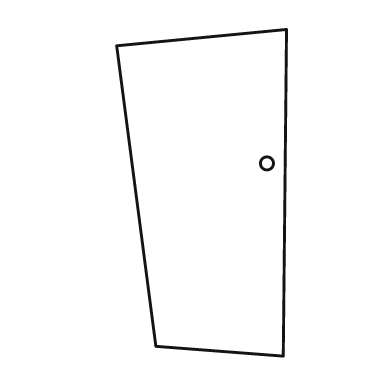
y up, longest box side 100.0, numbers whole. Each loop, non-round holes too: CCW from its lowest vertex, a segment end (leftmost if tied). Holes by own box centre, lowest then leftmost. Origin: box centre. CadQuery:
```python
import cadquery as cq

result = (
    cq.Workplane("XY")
    .moveTo(25.0, -50.0)
    .lineTo(26.0, 50.0)
    .lineTo(-26.0, 45.0)
    .lineTo(-14.0, -47.0)
    .close()
    .moveTo(20.0, 9.0)
    .circle(2.0)
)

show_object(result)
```